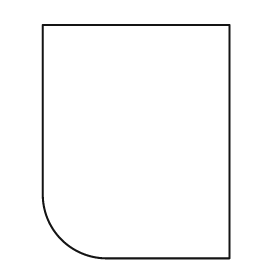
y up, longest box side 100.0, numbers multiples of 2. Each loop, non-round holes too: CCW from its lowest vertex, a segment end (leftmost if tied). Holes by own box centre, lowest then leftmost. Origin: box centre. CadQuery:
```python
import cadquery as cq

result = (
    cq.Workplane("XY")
    .moveTo(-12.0, -50.0)
    .lineTo(40.0, -50.0)
    .lineTo(40.0, 50.0)
    .lineTo(-40.0, 50.0)
    .lineTo(-40.0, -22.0)
    .threePointArc((-32.0, -42.0), (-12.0, -50.0))
    .close()
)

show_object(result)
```